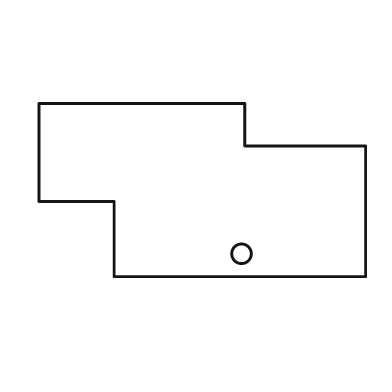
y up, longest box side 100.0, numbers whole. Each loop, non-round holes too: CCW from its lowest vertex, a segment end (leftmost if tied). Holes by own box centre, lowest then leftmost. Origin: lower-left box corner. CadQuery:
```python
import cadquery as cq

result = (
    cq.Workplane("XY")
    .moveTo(23.0, 0.0)
    .lineTo(100.0, 0.0)
    .lineTo(100.0, 40.0)
    .lineTo(63.0, 40.0)
    .lineTo(63.0, 53.0)
    .lineTo(0.0, 53.0)
    .lineTo(0.0, 23.0)
    .lineTo(23.0, 23.0)
    .close()
    .moveTo(62.0, 7.0)
    .circle(3.0)
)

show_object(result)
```